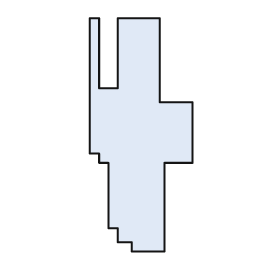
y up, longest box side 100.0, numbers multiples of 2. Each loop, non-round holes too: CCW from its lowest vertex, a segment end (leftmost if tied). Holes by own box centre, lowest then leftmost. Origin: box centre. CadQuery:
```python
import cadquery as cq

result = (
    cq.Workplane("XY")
    .moveTo(-4.0, -50.0)
    .lineTo(10.0, -50.0)
    .lineTo(10.0, -12.0)
    .lineTo(22.0, -12.0)
    .lineTo(22.0, 14.0)
    .lineTo(8.0, 14.0)
    .lineTo(8.0, 50.0)
    .lineTo(-10.0, 50.0)
    .lineTo(-10.0, 20.0)
    .lineTo(-18.0, 20.0)
    .lineTo(-18.0, 50.0)
    .lineTo(-22.0, 50.0)
    .lineTo(-22.0, -8.0)
    .lineTo(-18.0, -8.0)
    .lineTo(-18.0, -12.0)
    .lineTo(-14.0, -12.0)
    .lineTo(-14.0, -40.0)
    .lineTo(-10.0, -40.0)
    .lineTo(-10.0, -46.0)
    .lineTo(-4.0, -46.0)
    .close()
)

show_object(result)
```